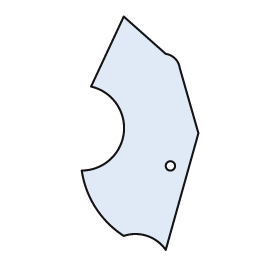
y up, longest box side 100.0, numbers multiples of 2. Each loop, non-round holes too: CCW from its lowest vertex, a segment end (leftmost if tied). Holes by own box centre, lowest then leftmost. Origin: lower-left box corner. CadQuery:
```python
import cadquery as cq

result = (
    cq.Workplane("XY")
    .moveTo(36.0, 0.0)
    .lineTo(50.0, 50.0)
    .lineTo(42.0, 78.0)
    .threePointArc((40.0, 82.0), (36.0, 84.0))
    .lineTo(18.0, 100.0)
    .lineTo(4.0, 70.0)
    .threePointArc((18.0, 50.0), (0.0, 34.0))
    .threePointArc((6.0, 18.0), (18.0, 6.0))
    .threePointArc((28.0, 6.0), (36.0, 0.0))
    .close()
    .moveTo(38.0, 36.0)
    .circle(2.0)
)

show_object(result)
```